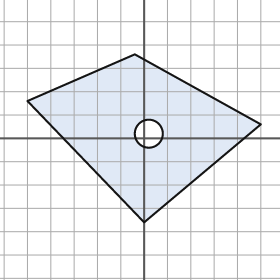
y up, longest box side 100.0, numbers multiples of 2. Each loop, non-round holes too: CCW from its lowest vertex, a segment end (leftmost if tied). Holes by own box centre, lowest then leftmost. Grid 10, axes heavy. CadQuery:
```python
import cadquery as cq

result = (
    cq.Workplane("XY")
    .moveTo(0.0, -36.0)
    .lineTo(50.0, 6.0)
    .lineTo(-4.0, 36.0)
    .lineTo(-50.0, 16.0)
    .close()
    .moveTo(2.0, 2.0)
    .circle(6.0)
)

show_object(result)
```